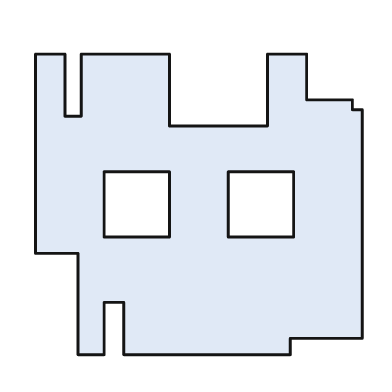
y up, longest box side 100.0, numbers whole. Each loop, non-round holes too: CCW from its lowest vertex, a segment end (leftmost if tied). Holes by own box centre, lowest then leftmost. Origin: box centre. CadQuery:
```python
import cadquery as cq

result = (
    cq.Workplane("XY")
    .moveTo(-37.0, -46.0)
    .lineTo(-29.0, -46.0)
    .lineTo(-29.0, -30.0)
    .lineTo(-23.0, -30.0)
    .lineTo(-23.0, -46.0)
    .lineTo(28.0, -46.0)
    .lineTo(28.0, -41.0)
    .lineTo(50.0, -41.0)
    .lineTo(50.0, 29.0)
    .lineTo(47.0, 29.0)
    .lineTo(47.0, 32.0)
    .lineTo(33.0, 32.0)
    .lineTo(33.0, 46.0)
    .lineTo(21.0, 46.0)
    .lineTo(21.0, 24.0)
    .lineTo(-9.0, 24.0)
    .lineTo(-9.0, 46.0)
    .lineTo(-36.0, 46.0)
    .lineTo(-36.0, 27.0)
    .lineTo(-41.0, 27.0)
    .lineTo(-41.0, 46.0)
    .lineTo(-50.0, 46.0)
    .lineTo(-50.0, -15.0)
    .lineTo(-37.0, -15.0)
    .close()
    .moveTo(-29.0, -10.0)
    .lineTo(-9.0, -10.0)
    .lineTo(-9.0, 10.0)
    .lineTo(-29.0, 10.0)
    .close()
    .moveTo(9.0, -10.0)
    .lineTo(29.0, -10.0)
    .lineTo(29.0, 10.0)
    .lineTo(9.0, 10.0)
    .close()
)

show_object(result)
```